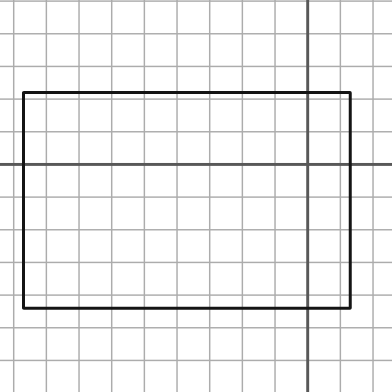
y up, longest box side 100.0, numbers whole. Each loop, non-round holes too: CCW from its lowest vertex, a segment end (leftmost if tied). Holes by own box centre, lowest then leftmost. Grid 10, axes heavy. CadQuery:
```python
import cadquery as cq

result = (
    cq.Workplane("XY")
    .moveTo(-87.0, -44.0)
    .lineTo(13.0, -44.0)
    .lineTo(13.0, 22.0)
    .lineTo(-87.0, 22.0)
    .close()
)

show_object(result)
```